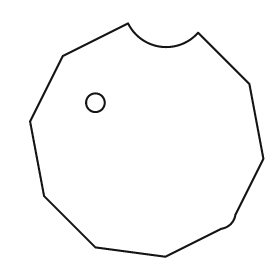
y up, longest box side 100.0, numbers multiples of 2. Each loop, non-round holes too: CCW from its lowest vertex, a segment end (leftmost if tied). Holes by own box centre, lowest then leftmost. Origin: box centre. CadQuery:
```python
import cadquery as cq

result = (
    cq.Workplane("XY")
    .moveTo(8.0, -50.0)
    .lineTo(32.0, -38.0)
    .threePointArc((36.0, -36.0), (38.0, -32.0))
    .lineTo(50.0, -8.0)
    .lineTo(44.0, 24.0)
    .lineTo(22.0, 46.0)
    .threePointArc((6.0, 40.0), (-8.0, 50.0))
    .lineTo(-36.0, 36.0)
    .lineTo(-50.0, 8.0)
    .lineTo(-44.0, -24.0)
    .lineTo(-22.0, -46.0)
    .close()
    .moveTo(-22.0, 16.0)
    .circle(4.0)
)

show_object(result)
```